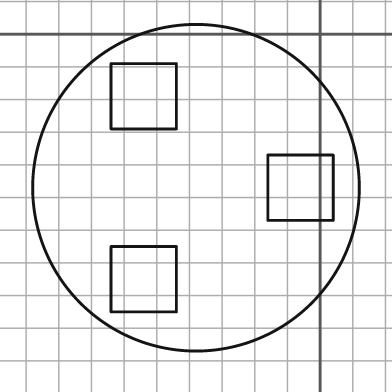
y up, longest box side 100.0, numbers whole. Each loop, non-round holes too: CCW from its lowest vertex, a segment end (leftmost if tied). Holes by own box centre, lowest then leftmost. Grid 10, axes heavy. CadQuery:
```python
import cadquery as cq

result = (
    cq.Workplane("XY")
    .moveTo(-38.0, -47.0)
    .circle(50.0)
    .moveTo(-64.0, -85.0)
    .lineTo(-44.0, -85.0)
    .lineTo(-44.0, -65.0)
    .lineTo(-64.0, -65.0)
    .close()
    .moveTo(-16.0, -57.0)
    .lineTo(4.0, -57.0)
    .lineTo(4.0, -37.0)
    .lineTo(-16.0, -37.0)
    .close()
    .moveTo(-64.0, -29.0)
    .lineTo(-44.0, -29.0)
    .lineTo(-44.0, -9.0)
    .lineTo(-64.0, -9.0)
    .close()
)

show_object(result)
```